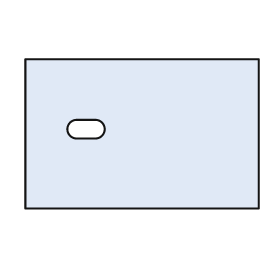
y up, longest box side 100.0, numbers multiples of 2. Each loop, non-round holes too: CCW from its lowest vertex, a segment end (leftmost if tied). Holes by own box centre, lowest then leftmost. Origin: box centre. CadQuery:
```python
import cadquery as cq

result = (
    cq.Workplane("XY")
    .moveTo(-50.0, -32.0)
    .lineTo(50.0, -32.0)
    .lineTo(50.0, 32.0)
    .lineTo(-50.0, 32.0)
    .close()
    .moveTo(-28.0, -2.0)
    .lineTo(-20.0, -2.0)
    .threePointArc((-16.0, 2.0), (-20.0, 6.0))
    .lineTo(-28.0, 6.0)
    .threePointArc((-32.0, 2.0), (-28.0, -2.0))
    .close()
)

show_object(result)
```